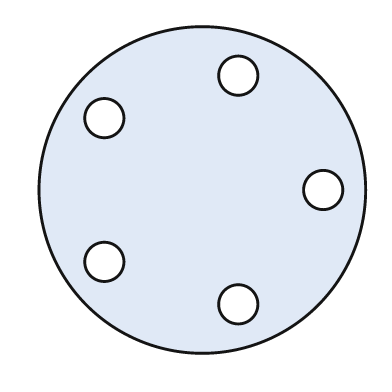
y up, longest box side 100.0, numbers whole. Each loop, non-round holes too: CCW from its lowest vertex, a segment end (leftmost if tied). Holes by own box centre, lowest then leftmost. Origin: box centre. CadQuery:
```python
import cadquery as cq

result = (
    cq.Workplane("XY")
    .moveTo(0.0, 0.0)
    .circle(50.0)
    .moveTo(11.0, -35.0)
    .circle(6.0)
    .moveTo(-30.0, -22.0)
    .circle(6.0)
    .moveTo(37.0, 0.0)
    .circle(6.0)
    .moveTo(-30.0, 22.0)
    .circle(6.0)
    .moveTo(11.0, 35.0)
    .circle(6.0)
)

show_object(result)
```